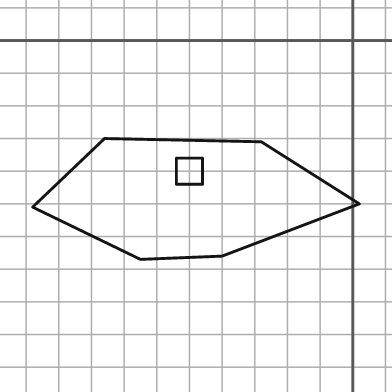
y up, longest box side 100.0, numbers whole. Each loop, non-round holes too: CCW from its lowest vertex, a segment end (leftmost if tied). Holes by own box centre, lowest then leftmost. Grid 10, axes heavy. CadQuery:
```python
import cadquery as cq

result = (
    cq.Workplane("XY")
    .moveTo(-65.0, -67.0)
    .lineTo(-40.0, -66.0)
    .lineTo(2.0, -50.0)
    .lineTo(-28.0, -31.0)
    .lineTo(-76.0, -30.0)
    .lineTo(-98.0, -51.0)
    .close()
    .moveTo(-54.0, -44.0)
    .lineTo(-46.0, -44.0)
    .lineTo(-46.0, -36.0)
    .lineTo(-54.0, -36.0)
    .close()
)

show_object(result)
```